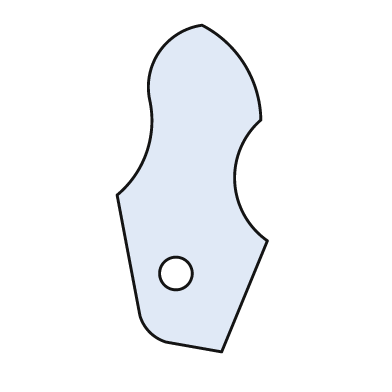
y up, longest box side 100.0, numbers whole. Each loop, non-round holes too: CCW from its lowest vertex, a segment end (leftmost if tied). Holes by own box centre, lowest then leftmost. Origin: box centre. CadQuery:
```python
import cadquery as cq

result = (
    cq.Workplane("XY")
    .moveTo(9.0, -50.0)
    .lineTo(23.0, -16.0)
    .threePointArc((13.0, 2.0), (21.0, 21.0))
    .threePointArc((16.0, 38.0), (3.0, 50.0))
    .threePointArc((-10.0, 42.0), (-13.0, 27.0))
    .threePointArc((-14.0, 11.0), (-23.0, -2.0))
    .lineTo(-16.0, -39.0)
    .threePointArc((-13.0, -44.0), (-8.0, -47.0))
    .close()
    .moveTo(-5.0, -26.0)
    .circle(5.0)
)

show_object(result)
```